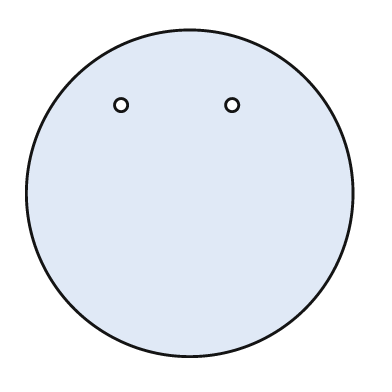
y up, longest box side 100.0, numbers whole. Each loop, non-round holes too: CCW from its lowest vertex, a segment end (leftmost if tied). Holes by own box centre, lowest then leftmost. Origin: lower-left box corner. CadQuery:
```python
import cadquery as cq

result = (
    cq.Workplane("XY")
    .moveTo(50.0, 50.0)
    .circle(50.0)
    .moveTo(29.0, 77.0)
    .circle(2.0)
    .moveTo(63.0, 77.0)
    .circle(2.0)
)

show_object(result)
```